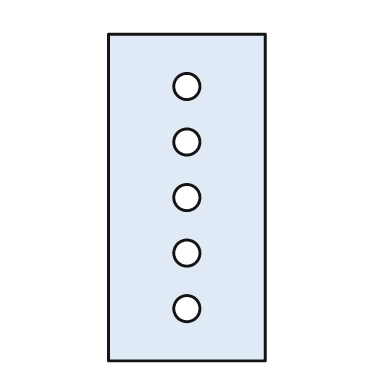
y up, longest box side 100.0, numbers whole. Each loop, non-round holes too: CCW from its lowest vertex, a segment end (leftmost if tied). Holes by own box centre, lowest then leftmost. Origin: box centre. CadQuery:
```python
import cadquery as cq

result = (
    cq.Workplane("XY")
    .moveTo(-24.0, -50.0)
    .lineTo(24.0, -50.0)
    .lineTo(24.0, 50.0)
    .lineTo(-24.0, 50.0)
    .close()
    .moveTo(0.0, -34.0)
    .circle(4.0)
    .moveTo(0.0, -17.0)
    .circle(4.0)
    .moveTo(0.0, 0.0)
    .circle(4.0)
    .moveTo(0.0, 17.0)
    .circle(4.0)
    .moveTo(0.0, 34.0)
    .circle(4.0)
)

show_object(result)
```